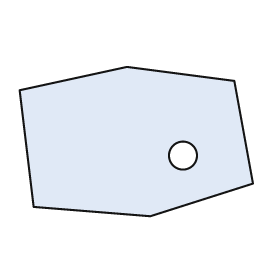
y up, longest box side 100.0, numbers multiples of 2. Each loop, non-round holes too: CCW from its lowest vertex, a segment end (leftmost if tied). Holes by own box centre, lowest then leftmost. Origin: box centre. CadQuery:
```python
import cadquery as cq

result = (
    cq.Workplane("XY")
    .moveTo(6.0, -32.0)
    .lineTo(50.0, -18.0)
    .lineTo(42.0, 26.0)
    .lineTo(-4.0, 32.0)
    .lineTo(-50.0, 22.0)
    .lineTo(-44.0, -28.0)
    .close()
    .moveTo(20.0, -6.0)
    .circle(6.0)
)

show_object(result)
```